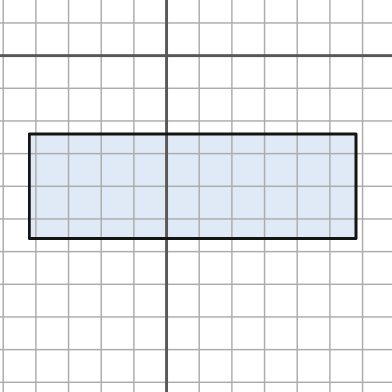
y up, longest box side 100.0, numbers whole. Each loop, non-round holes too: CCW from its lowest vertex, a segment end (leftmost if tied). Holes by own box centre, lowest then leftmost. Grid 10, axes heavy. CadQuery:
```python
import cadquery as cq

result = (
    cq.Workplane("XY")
    .moveTo(-42.0, -56.0)
    .lineTo(58.0, -56.0)
    .lineTo(58.0, -24.0)
    .lineTo(-42.0, -24.0)
    .close()
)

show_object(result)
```